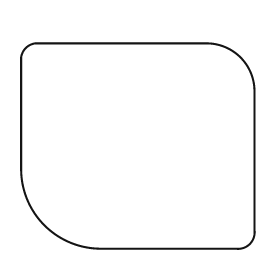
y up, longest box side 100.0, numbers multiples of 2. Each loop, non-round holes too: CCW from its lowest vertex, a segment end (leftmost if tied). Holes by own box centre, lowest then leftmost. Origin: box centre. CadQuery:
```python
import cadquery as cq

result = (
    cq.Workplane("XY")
    .moveTo(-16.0, -44.0)
    .lineTo(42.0, -44.0)
    .threePointArc((48.0, -42.0), (50.0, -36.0))
    .lineTo(50.0, 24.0)
    .threePointArc((44.0, 38.0), (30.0, 44.0))
    .lineTo(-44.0, 44.0)
    .threePointArc((-48.0, 42.0), (-50.0, 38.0))
    .lineTo(-50.0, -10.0)
    .threePointArc((-40.0, -34.0), (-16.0, -44.0))
    .close()
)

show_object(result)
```